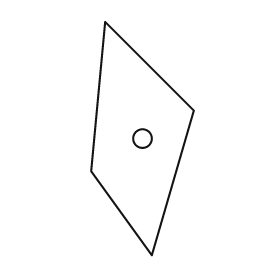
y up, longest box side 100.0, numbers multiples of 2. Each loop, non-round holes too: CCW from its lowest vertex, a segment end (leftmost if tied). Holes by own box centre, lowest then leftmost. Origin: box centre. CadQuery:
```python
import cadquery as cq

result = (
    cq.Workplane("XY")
    .moveTo(4.0, -50.0)
    .lineTo(22.0, 12.0)
    .lineTo(-16.0, 50.0)
    .lineTo(-22.0, -14.0)
    .close()
    .moveTo(0.0, 0.0)
    .circle(4.0)
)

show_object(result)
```